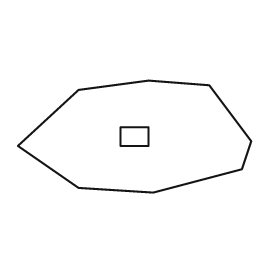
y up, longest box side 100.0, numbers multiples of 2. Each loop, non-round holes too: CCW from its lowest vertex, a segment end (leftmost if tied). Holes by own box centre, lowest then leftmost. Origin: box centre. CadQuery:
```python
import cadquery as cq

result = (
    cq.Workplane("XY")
    .moveTo(8.0, -24.0)
    .lineTo(46.0, -14.0)
    .lineTo(50.0, -2.0)
    .lineTo(32.0, 22.0)
    .lineTo(6.0, 24.0)
    .lineTo(-24.0, 20.0)
    .lineTo(-50.0, -4.0)
    .lineTo(-24.0, -22.0)
    .close()
    .moveTo(-6.0, -4.0)
    .lineTo(6.0, -4.0)
    .lineTo(6.0, 4.0)
    .lineTo(-6.0, 4.0)
    .close()
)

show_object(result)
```